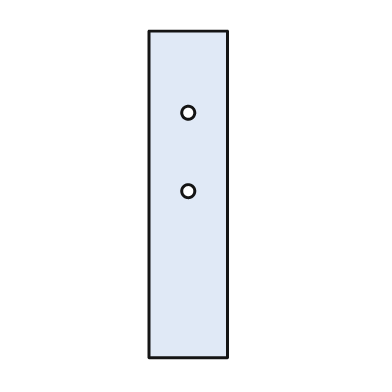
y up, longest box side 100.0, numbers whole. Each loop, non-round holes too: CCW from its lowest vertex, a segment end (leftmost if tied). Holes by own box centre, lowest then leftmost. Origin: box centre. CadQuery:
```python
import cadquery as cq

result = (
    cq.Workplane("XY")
    .moveTo(-12.0, -50.0)
    .lineTo(12.0, -50.0)
    .lineTo(12.0, 50.0)
    .lineTo(-12.0, 50.0)
    .close()
    .moveTo(0.0, 1.0)
    .circle(2.0)
    .moveTo(0.0, 25.0)
    .circle(2.0)
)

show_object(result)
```